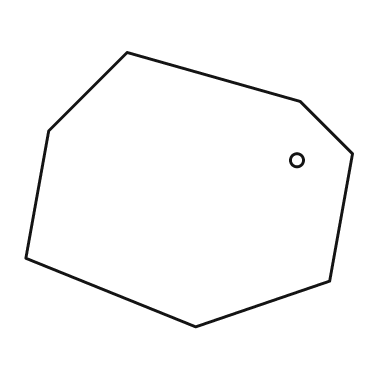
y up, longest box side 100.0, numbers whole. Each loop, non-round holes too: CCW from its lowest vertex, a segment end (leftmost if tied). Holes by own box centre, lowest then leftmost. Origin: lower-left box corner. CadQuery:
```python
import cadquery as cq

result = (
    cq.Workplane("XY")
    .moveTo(52.0, 0.0)
    .lineTo(93.0, 14.0)
    .lineTo(100.0, 53.0)
    .lineTo(84.0, 69.0)
    .lineTo(31.0, 84.0)
    .lineTo(7.0, 60.0)
    .lineTo(0.0, 21.0)
    .close()
    .moveTo(83.0, 51.0)
    .circle(2.0)
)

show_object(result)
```